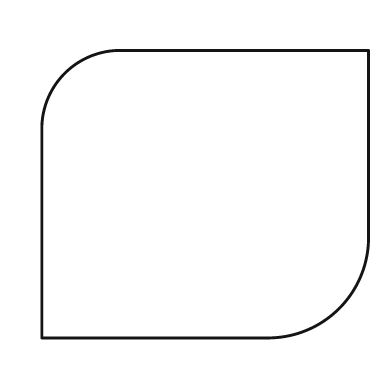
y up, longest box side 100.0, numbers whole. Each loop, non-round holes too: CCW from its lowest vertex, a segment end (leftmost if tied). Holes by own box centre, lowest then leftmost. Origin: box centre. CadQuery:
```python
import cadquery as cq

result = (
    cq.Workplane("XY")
    .moveTo(-50.0, -44.0)
    .lineTo(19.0, -44.0)
    .threePointArc((41.0, -35.0), (50.0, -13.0))
    .lineTo(50.0, 44.0)
    .lineTo(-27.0, 44.0)
    .threePointArc((-43.0, 37.0), (-50.0, 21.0))
    .close()
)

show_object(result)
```